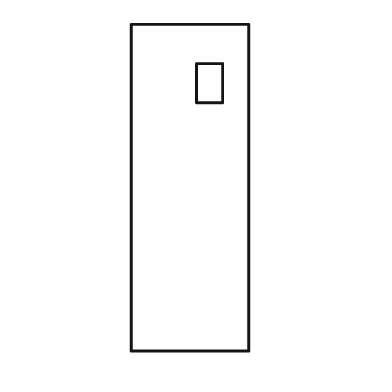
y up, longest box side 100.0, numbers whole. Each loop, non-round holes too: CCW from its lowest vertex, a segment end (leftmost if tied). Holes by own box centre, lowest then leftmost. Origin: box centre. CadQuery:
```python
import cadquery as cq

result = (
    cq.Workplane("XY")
    .moveTo(-18.0, -50.0)
    .lineTo(18.0, -50.0)
    .lineTo(18.0, 50.0)
    .lineTo(-18.0, 50.0)
    .close()
    .moveTo(2.0, 26.0)
    .lineTo(10.0, 26.0)
    .lineTo(10.0, 38.0)
    .lineTo(2.0, 38.0)
    .close()
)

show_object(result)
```